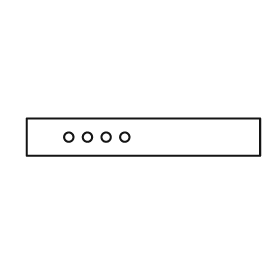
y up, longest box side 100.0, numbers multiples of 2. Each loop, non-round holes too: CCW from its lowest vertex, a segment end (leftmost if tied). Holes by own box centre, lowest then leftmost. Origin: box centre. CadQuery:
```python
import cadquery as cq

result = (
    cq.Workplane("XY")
    .moveTo(-50.0, -8.0)
    .lineTo(50.0, -8.0)
    .lineTo(50.0, 8.0)
    .lineTo(-50.0, 8.0)
    .close()
    .moveTo(-32.0, 0.0)
    .circle(2.0)
    .moveTo(-24.0, 0.0)
    .circle(2.0)
    .moveTo(-16.0, 0.0)
    .circle(2.0)
    .moveTo(-8.0, 0.0)
    .circle(2.0)
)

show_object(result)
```